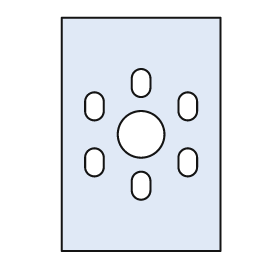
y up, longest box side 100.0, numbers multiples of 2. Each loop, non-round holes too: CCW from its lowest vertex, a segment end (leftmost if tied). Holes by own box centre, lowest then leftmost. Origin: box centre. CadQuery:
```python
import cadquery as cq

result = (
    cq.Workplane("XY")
    .moveTo(-34.0, -50.0)
    .lineTo(34.0, -50.0)
    .lineTo(34.0, 50.0)
    .lineTo(-34.0, 50.0)
    .close()
    .moveTo(-4.0, -24.0)
    .threePointArc((0.0, -28.0), (4.0, -24.0))
    .lineTo(4.0, -20.0)
    .threePointArc((0.0, -16.0), (-4.0, -20.0))
    .close()
    .moveTo(-24.0, -14.0)
    .threePointArc((-20.0, -18.0), (-16.0, -14.0))
    .lineTo(-16.0, -10.0)
    .threePointArc((-20.0, -6.0), (-24.0, -10.0))
    .close()
    .moveTo(16.0, -14.0)
    .threePointArc((20.0, -18.0), (24.0, -14.0))
    .lineTo(24.0, -10.0)
    .threePointArc((20.0, -6.0), (16.0, -10.0))
    .close()
    .moveTo(0.0, 0.0)
    .circle(10.0)
    .moveTo(-24.0, 10.0)
    .threePointArc((-20.0, 6.0), (-16.0, 10.0))
    .lineTo(-16.0, 14.0)
    .threePointArc((-20.0, 18.0), (-24.0, 14.0))
    .close()
    .moveTo(16.0, 10.0)
    .threePointArc((20.0, 6.0), (24.0, 10.0))
    .lineTo(24.0, 14.0)
    .threePointArc((20.0, 18.0), (16.0, 14.0))
    .close()
    .moveTo(-4.0, 20.0)
    .threePointArc((0.0, 16.0), (4.0, 20.0))
    .lineTo(4.0, 24.0)
    .threePointArc((0.0, 28.0), (-4.0, 24.0))
    .close()
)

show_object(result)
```